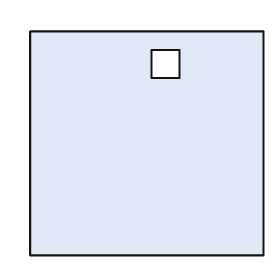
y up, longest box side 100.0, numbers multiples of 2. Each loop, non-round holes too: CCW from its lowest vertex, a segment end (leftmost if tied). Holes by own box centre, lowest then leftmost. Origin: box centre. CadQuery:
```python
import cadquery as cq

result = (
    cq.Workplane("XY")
    .moveTo(-50.0, -48.0)
    .lineTo(50.0, -48.0)
    .lineTo(50.0, 48.0)
    .lineTo(-50.0, 48.0)
    .close()
    .moveTo(2.0, 28.0)
    .lineTo(14.0, 28.0)
    .lineTo(14.0, 40.0)
    .lineTo(2.0, 40.0)
    .close()
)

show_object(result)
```